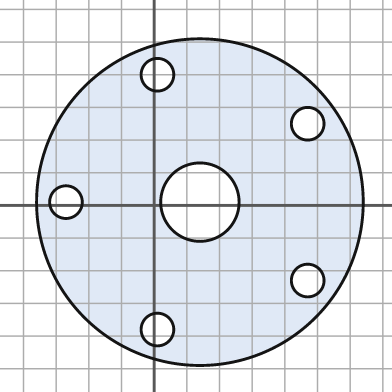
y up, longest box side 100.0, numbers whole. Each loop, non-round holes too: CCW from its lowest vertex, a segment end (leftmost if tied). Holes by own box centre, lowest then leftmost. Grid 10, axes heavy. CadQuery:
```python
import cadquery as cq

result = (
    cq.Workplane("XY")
    .moveTo(14.0, 1.0)
    .circle(50.0)
    .moveTo(1.0, -38.0)
    .circle(5.0)
    .moveTo(47.0, -23.0)
    .circle(5.0)
    .moveTo(-27.0, 1.0)
    .circle(5.0)
    .moveTo(14.0, 1.0)
    .circle(12.0)
    .moveTo(47.0, 25.0)
    .circle(5.0)
    .moveTo(1.0, 40.0)
    .circle(5.0)
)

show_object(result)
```